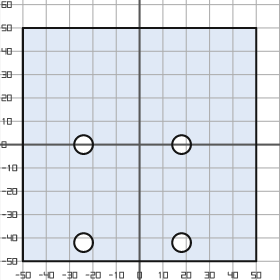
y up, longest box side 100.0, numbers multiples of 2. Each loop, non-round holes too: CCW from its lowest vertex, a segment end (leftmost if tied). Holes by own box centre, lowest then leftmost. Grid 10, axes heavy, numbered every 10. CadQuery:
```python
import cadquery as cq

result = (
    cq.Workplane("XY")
    .moveTo(-50.0, -50.0)
    .lineTo(50.0, -50.0)
    .lineTo(50.0, 50.0)
    .lineTo(-50.0, 50.0)
    .close()
    .moveTo(-24.0, -42.0)
    .circle(4.0)
    .moveTo(18.0, -42.0)
    .circle(4.0)
    .moveTo(-24.0, 0.0)
    .circle(4.0)
    .moveTo(18.0, 0.0)
    .circle(4.0)
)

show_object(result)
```